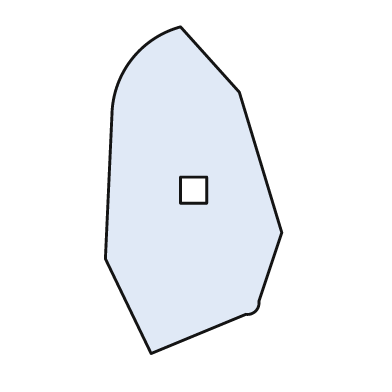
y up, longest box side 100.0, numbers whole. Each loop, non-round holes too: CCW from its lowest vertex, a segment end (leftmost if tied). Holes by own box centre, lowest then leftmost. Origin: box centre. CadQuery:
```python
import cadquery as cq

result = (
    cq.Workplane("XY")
    .moveTo(-13.0, -50.0)
    .lineTo(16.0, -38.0)
    .threePointArc((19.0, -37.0), (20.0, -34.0))
    .lineTo(27.0, -13.0)
    .lineTo(14.0, 30.0)
    .lineTo(-4.0, 50.0)
    .threePointArc((-19.0, 40.0), (-25.0, 23.0))
    .lineTo(-27.0, -21.0)
    .close()
    .moveTo(-4.0, -4.0)
    .lineTo(4.0, -4.0)
    .lineTo(4.0, 4.0)
    .lineTo(-4.0, 4.0)
    .close()
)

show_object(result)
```